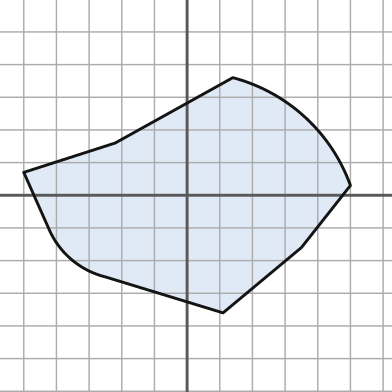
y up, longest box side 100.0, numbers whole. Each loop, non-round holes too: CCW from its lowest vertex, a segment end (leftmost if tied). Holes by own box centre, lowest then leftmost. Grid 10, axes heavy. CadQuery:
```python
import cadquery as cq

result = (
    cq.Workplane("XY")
    .moveTo(11.0, -36.0)
    .lineTo(35.0, -16.0)
    .lineTo(50.0, 3.0)
    .threePointArc((36.0, 24.0), (14.0, 36.0))
    .lineTo(-22.0, 16.0)
    .lineTo(-50.0, 7.0)
    .lineTo(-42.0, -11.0)
    .threePointArc((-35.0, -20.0), (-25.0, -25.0))
    .close()
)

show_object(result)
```